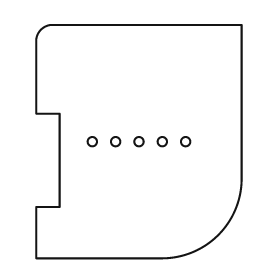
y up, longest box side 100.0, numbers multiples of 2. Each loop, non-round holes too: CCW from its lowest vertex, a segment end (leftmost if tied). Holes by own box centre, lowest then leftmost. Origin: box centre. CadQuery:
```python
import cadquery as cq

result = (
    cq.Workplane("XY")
    .moveTo(-44.0, -50.0)
    .lineTo(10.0, -50.0)
    .threePointArc((34.0, -40.0), (44.0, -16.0))
    .lineTo(44.0, 50.0)
    .lineTo(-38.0, 50.0)
    .threePointArc((-42.0, 48.0), (-44.0, 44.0))
    .lineTo(-44.0, 12.0)
    .lineTo(-34.0, 12.0)
    .lineTo(-34.0, -28.0)
    .lineTo(-44.0, -28.0)
    .close()
    .moveTo(-20.0, 0.0)
    .circle(2.0)
    .moveTo(-10.0, 0.0)
    .circle(2.0)
    .moveTo(0.0, 0.0)
    .circle(2.0)
    .moveTo(10.0, 0.0)
    .circle(2.0)
    .moveTo(20.0, 0.0)
    .circle(2.0)
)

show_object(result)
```